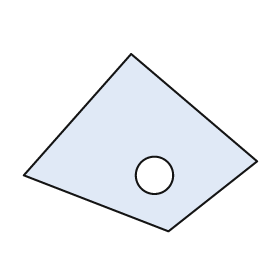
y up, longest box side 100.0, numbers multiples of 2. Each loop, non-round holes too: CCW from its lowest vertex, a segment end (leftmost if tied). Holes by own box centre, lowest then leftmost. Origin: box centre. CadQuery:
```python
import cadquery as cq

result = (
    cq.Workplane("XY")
    .moveTo(12.0, -38.0)
    .lineTo(50.0, -8.0)
    .lineTo(-4.0, 38.0)
    .lineTo(-50.0, -14.0)
    .close()
    .moveTo(6.0, -14.0)
    .circle(8.0)
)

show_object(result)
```